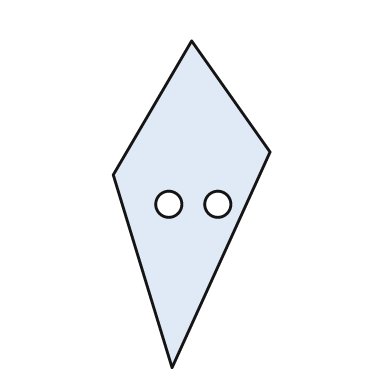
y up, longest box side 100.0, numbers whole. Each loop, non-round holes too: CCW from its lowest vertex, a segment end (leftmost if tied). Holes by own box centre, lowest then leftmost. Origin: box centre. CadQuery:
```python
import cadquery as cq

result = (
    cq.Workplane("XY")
    .moveTo(-6.0, -50.0)
    .lineTo(24.0, 16.0)
    .lineTo(0.0, 50.0)
    .lineTo(-24.0, 9.0)
    .close()
    .moveTo(-7.0, 0.0)
    .circle(4.0)
    .moveTo(8.0, 0.0)
    .circle(4.0)
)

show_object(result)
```